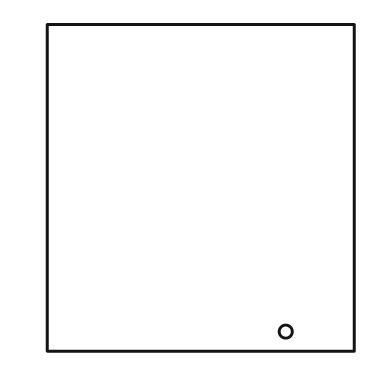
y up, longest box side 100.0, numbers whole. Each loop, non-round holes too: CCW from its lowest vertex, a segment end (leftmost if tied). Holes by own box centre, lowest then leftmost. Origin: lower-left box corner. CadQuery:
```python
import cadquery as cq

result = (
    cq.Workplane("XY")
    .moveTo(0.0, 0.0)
    .lineTo(94.0, 0.0)
    .lineTo(94.0, 100.0)
    .lineTo(0.0, 100.0)
    .close()
    .moveTo(73.0, 6.0)
    .circle(2.0)
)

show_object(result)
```